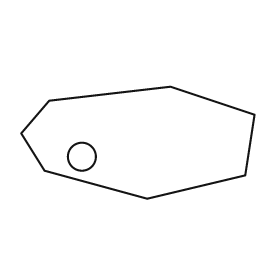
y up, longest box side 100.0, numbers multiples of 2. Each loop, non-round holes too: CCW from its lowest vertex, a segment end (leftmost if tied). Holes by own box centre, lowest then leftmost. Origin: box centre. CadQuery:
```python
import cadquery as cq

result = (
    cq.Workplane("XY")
    .moveTo(4.0, -24.0)
    .lineTo(46.0, -14.0)
    .lineTo(50.0, 12.0)
    .lineTo(14.0, 24.0)
    .lineTo(-38.0, 18.0)
    .lineTo(-50.0, 4.0)
    .lineTo(-40.0, -12.0)
    .close()
    .moveTo(-24.0, -6.0)
    .circle(6.0)
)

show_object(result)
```